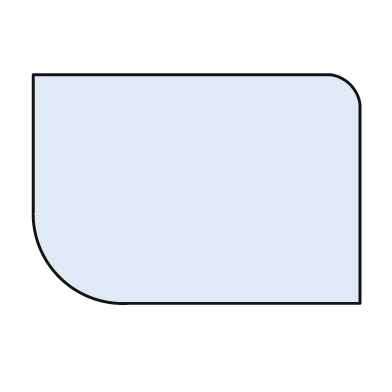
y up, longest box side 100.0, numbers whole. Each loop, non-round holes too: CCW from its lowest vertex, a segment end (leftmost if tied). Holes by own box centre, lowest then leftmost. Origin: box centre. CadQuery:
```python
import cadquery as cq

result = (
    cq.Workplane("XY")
    .moveTo(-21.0, -35.0)
    .lineTo(50.0, -35.0)
    .lineTo(50.0, 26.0)
    .threePointArc((47.0, 32.0), (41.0, 35.0))
    .lineTo(-50.0, 35.0)
    .lineTo(-50.0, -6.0)
    .threePointArc((-42.0, -27.0), (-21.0, -35.0))
    .close()
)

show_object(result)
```